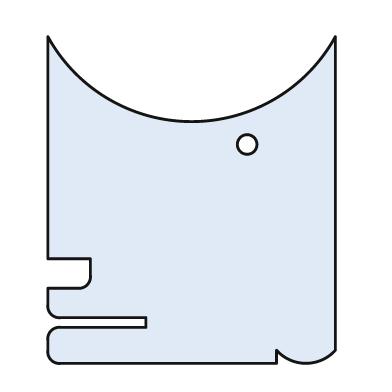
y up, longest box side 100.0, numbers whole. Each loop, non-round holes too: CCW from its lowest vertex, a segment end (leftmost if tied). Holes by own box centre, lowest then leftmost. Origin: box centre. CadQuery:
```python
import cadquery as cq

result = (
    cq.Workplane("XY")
    .moveTo(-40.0, -50.0)
    .lineTo(26.0, -50.0)
    .lineTo(26.0, -46.0)
    .threePointArc((35.0, -50.0), (44.0, -46.0))
    .lineTo(44.0, 50.0)
    .threePointArc((0.0, 24.0), (-44.0, 50.0))
    .lineTo(-44.0, -18.0)
    .lineTo(-31.0, -18.0)
    .lineTo(-31.0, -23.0)
    .threePointArc((-32.0, -26.0), (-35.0, -27.0))
    .lineTo(-44.0, -27.0)
    .lineTo(-44.0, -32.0)
    .threePointArc((-43.0, -35.0), (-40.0, -36.0))
    .lineTo(-14.0, -36.0)
    .lineTo(-14.0, -39.0)
    .lineTo(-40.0, -39.0)
    .threePointArc((-43.0, -40.0), (-44.0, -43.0))
    .lineTo(-44.0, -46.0)
    .threePointArc((-43.0, -49.0), (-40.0, -50.0))
    .close()
    .moveTo(17.0, 17.0)
    .circle(3.0)
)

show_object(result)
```